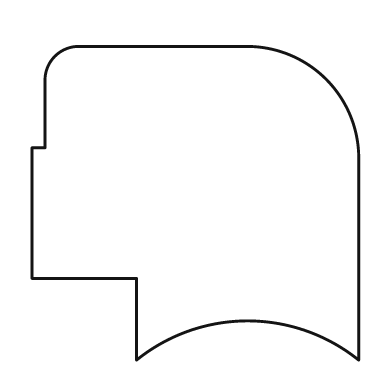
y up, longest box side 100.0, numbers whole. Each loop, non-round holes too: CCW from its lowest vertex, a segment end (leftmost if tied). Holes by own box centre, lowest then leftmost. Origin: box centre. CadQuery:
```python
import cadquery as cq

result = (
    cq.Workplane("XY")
    .moveTo(-18.0, -48.0)
    .threePointArc((16.0, -36.0), (50.0, -48.0))
    .lineTo(50.0, 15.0)
    .threePointArc((40.0, 38.0), (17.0, 48.0))
    .lineTo(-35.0, 48.0)
    .threePointArc((-43.0, 45.0), (-46.0, 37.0))
    .lineTo(-46.0, 17.0)
    .lineTo(-50.0, 17.0)
    .lineTo(-50.0, -23.0)
    .lineTo(-18.0, -23.0)
    .close()
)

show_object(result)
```